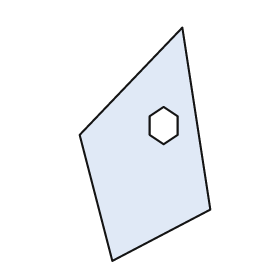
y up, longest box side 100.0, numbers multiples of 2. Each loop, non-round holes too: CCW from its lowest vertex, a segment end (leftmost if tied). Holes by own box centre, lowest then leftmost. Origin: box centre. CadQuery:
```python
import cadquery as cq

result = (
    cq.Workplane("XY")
    .moveTo(-14.0, -50.0)
    .lineTo(28.0, -28.0)
    .lineTo(16.0, 50.0)
    .lineTo(-28.0, 4.0)
    .close()
    .moveTo(8.0, 0.0)
    .lineTo(14.0, 4.0)
    .lineTo(14.0, 12.0)
    .lineTo(8.0, 16.0)
    .lineTo(2.0, 12.0)
    .lineTo(2.0, 4.0)
    .close()
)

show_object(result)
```